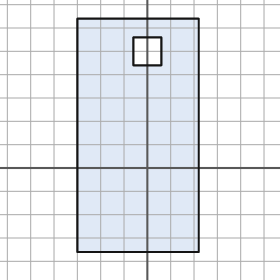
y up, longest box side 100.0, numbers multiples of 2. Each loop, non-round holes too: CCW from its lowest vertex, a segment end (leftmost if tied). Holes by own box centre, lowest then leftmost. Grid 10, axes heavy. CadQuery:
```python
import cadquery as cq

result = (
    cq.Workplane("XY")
    .moveTo(-30.0, -36.0)
    .lineTo(22.0, -36.0)
    .lineTo(22.0, 64.0)
    .lineTo(-30.0, 64.0)
    .close()
    .moveTo(-6.0, 44.0)
    .lineTo(6.0, 44.0)
    .lineTo(6.0, 56.0)
    .lineTo(-6.0, 56.0)
    .close()
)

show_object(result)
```